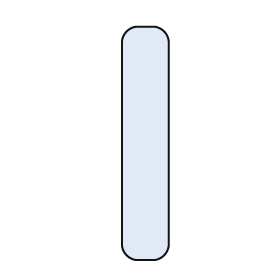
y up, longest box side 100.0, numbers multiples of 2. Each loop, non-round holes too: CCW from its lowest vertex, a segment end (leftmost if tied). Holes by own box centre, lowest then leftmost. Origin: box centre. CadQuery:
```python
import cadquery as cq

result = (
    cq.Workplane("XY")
    .moveTo(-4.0, -50.0)
    .lineTo(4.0, -50.0)
    .threePointArc((8.0, -48.0), (10.0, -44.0))
    .lineTo(10.0, 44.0)
    .threePointArc((8.0, 48.0), (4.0, 50.0))
    .lineTo(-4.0, 50.0)
    .threePointArc((-8.0, 48.0), (-10.0, 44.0))
    .lineTo(-10.0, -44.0)
    .threePointArc((-8.0, -48.0), (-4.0, -50.0))
    .close()
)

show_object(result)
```